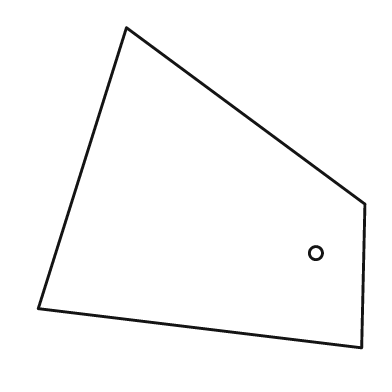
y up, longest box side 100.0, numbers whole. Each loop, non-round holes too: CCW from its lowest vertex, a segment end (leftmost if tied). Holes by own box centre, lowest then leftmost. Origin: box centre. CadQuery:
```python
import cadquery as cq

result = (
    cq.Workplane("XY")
    .moveTo(49.0, -49.0)
    .lineTo(50.0, -5.0)
    .lineTo(-23.0, 49.0)
    .lineTo(-50.0, -37.0)
    .close()
    .moveTo(35.0, -20.0)
    .circle(2.0)
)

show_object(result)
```